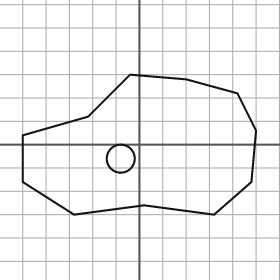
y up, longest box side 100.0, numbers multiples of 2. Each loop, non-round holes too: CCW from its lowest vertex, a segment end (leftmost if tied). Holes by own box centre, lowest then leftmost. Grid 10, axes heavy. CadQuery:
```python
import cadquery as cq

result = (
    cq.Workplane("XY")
    .moveTo(-28.0, -30.0)
    .lineTo(2.0, -26.0)
    .lineTo(32.0, -30.0)
    .lineTo(48.0, -16.0)
    .lineTo(50.0, 6.0)
    .lineTo(42.0, 22.0)
    .lineTo(20.0, 28.0)
    .lineTo(-4.0, 30.0)
    .lineTo(-22.0, 12.0)
    .lineTo(-50.0, 4.0)
    .lineTo(-50.0, -16.0)
    .close()
    .moveTo(-8.0, -6.0)
    .circle(6.0)
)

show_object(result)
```